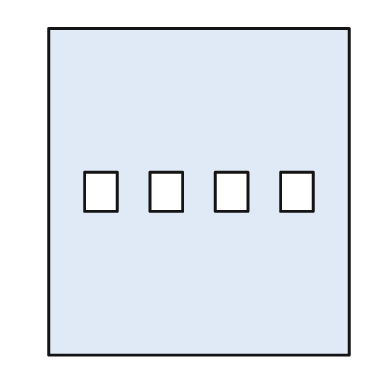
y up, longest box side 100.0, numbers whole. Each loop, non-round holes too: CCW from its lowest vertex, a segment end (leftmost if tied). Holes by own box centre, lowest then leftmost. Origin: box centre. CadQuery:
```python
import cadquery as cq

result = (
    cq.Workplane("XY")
    .moveTo(-46.0, -50.0)
    .lineTo(46.0, -50.0)
    .lineTo(46.0, 50.0)
    .lineTo(-46.0, 50.0)
    .close()
    .moveTo(-35.0, -6.0)
    .lineTo(-25.0, -6.0)
    .lineTo(-25.0, 6.0)
    .lineTo(-35.0, 6.0)
    .close()
    .moveTo(-15.0, -6.0)
    .lineTo(-5.0, -6.0)
    .lineTo(-5.0, 6.0)
    .lineTo(-15.0, 6.0)
    .close()
    .moveTo(5.0, -6.0)
    .lineTo(15.0, -6.0)
    .lineTo(15.0, 6.0)
    .lineTo(5.0, 6.0)
    .close()
    .moveTo(25.0, -6.0)
    .lineTo(35.0, -6.0)
    .lineTo(35.0, 6.0)
    .lineTo(25.0, 6.0)
    .close()
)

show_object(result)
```